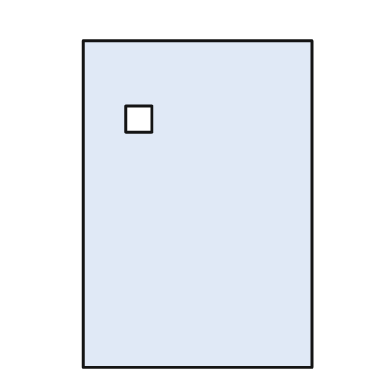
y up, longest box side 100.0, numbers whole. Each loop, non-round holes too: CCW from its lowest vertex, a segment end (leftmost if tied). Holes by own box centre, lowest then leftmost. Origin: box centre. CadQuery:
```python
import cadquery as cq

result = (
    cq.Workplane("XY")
    .moveTo(-35.0, -50.0)
    .lineTo(35.0, -50.0)
    .lineTo(35.0, 50.0)
    .lineTo(-35.0, 50.0)
    .close()
    .moveTo(-22.0, 22.0)
    .lineTo(-14.0, 22.0)
    .lineTo(-14.0, 30.0)
    .lineTo(-22.0, 30.0)
    .close()
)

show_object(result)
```